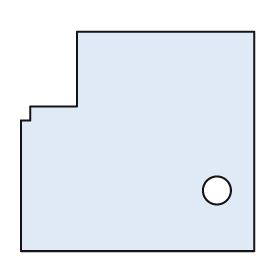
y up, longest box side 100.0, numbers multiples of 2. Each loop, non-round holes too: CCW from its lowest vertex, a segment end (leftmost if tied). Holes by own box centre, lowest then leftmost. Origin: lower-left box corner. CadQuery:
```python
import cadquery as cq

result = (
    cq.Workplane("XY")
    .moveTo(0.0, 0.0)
    .lineTo(100.0, 0.0)
    .lineTo(100.0, 94.0)
    .lineTo(24.0, 94.0)
    .lineTo(24.0, 62.0)
    .lineTo(4.0, 62.0)
    .lineTo(4.0, 56.0)
    .lineTo(0.0, 56.0)
    .close()
    .moveTo(84.0, 26.0)
    .circle(6.0)
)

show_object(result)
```